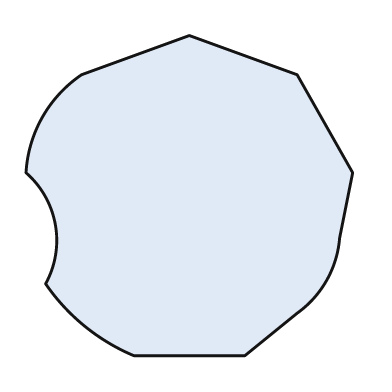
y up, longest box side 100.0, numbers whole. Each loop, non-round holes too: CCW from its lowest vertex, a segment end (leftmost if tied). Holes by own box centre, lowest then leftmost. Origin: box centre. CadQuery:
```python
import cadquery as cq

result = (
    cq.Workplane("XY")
    .moveTo(-17.0, -49.0)
    .lineTo(17.0, -49.0)
    .lineTo(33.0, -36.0)
    .threePointArc((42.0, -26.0), (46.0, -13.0))
    .lineTo(50.0, 7.0)
    .lineTo(33.0, 37.0)
    .lineTo(0.0, 49.0)
    .lineTo(-33.0, 37.0)
    .threePointArc((-45.0, 24.0), (-50.0, 7.0))
    .threePointArc((-41.0, -9.0), (-44.0, -27.0))
    .threePointArc((-32.0, -40.0), (-17.0, -49.0))
    .close()
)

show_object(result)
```